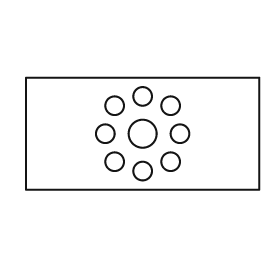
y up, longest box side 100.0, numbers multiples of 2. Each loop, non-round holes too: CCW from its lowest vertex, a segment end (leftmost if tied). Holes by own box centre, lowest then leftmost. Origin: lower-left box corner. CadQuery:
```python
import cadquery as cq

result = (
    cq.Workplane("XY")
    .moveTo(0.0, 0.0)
    .lineTo(100.0, 0.0)
    .lineTo(100.0, 48.0)
    .lineTo(0.0, 48.0)
    .close()
    .moveTo(50.0, 8.0)
    .circle(4.0)
    .moveTo(38.0, 12.0)
    .circle(4.0)
    .moveTo(62.0, 12.0)
    .circle(4.0)
    .moveTo(34.0, 24.0)
    .circle(4.0)
    .moveTo(50.0, 24.0)
    .circle(6.0)
    .moveTo(66.0, 24.0)
    .circle(4.0)
    .moveTo(38.0, 36.0)
    .circle(4.0)
    .moveTo(62.0, 36.0)
    .circle(4.0)
    .moveTo(50.0, 40.0)
    .circle(4.0)
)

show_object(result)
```